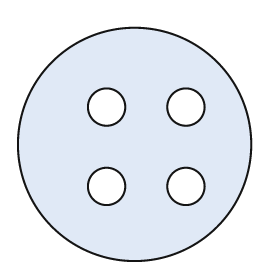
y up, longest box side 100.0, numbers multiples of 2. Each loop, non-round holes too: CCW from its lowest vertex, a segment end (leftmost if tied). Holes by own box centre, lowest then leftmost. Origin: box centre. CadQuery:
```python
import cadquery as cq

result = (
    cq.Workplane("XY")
    .moveTo(0.0, 0.0)
    .circle(50.0)
    .moveTo(-12.0, -18.0)
    .circle(8.0)
    .moveTo(22.0, -18.0)
    .circle(8.0)
    .moveTo(-12.0, 16.0)
    .circle(8.0)
    .moveTo(22.0, 16.0)
    .circle(8.0)
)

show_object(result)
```